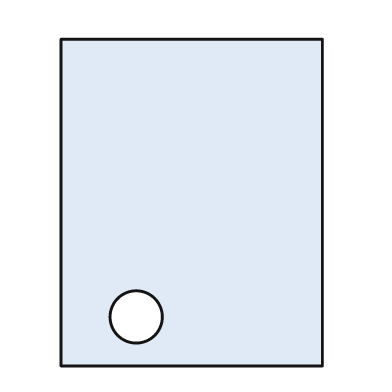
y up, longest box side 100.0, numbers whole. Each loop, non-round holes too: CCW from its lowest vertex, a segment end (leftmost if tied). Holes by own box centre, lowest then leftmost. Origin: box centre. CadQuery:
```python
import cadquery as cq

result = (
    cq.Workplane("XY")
    .moveTo(-40.0, -50.0)
    .lineTo(40.0, -50.0)
    .lineTo(40.0, 50.0)
    .lineTo(-40.0, 50.0)
    .close()
    .moveTo(-17.0, -35.0)
    .circle(8.0)
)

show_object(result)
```